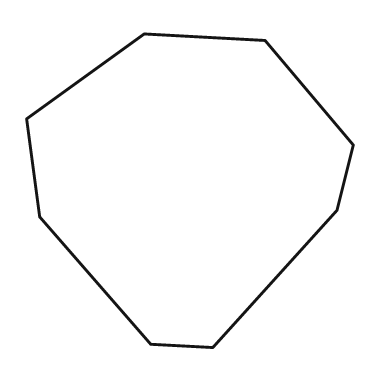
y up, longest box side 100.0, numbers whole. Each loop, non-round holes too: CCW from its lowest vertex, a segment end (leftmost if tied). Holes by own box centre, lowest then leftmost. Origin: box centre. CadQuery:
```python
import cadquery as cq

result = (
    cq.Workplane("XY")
    .moveTo(7.0, -48.0)
    .lineTo(45.0, -6.0)
    .lineTo(50.0, 14.0)
    .lineTo(23.0, 46.0)
    .lineTo(-14.0, 48.0)
    .lineTo(-50.0, 22.0)
    .lineTo(-46.0, -8.0)
    .lineTo(-12.0, -47.0)
    .close()
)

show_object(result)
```